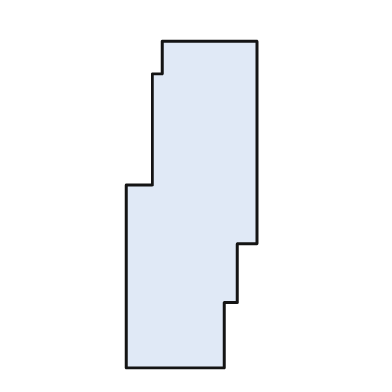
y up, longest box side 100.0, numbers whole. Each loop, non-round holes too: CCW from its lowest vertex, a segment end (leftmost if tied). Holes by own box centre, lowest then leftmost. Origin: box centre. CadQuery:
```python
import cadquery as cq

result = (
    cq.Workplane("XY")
    .moveTo(-20.0, -50.0)
    .lineTo(10.0, -50.0)
    .lineTo(10.0, -30.0)
    .lineTo(14.0, -30.0)
    .lineTo(14.0, -12.0)
    .lineTo(20.0, -12.0)
    .lineTo(20.0, 50.0)
    .lineTo(-9.0, 50.0)
    .lineTo(-9.0, 40.0)
    .lineTo(-12.0, 40.0)
    .lineTo(-12.0, 6.0)
    .lineTo(-20.0, 6.0)
    .close()
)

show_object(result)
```